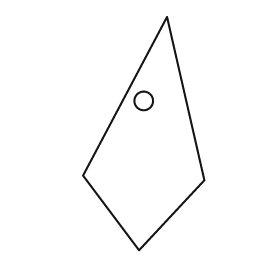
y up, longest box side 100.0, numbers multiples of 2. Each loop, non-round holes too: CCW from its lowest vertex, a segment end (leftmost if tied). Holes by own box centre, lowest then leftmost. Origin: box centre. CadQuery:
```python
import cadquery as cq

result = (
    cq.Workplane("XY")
    .moveTo(-2.0, -50.0)
    .lineTo(26.0, -20.0)
    .lineTo(10.0, 50.0)
    .lineTo(-26.0, -18.0)
    .close()
    .moveTo(0.0, 14.0)
    .circle(4.0)
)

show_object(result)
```